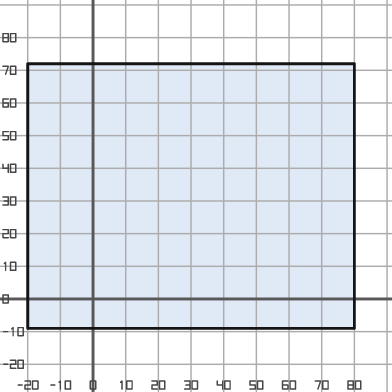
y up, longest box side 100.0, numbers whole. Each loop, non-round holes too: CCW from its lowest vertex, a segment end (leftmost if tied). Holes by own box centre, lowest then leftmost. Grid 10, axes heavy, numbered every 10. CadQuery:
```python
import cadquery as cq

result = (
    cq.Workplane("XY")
    .moveTo(-20.0, -9.0)
    .lineTo(80.0, -9.0)
    .lineTo(80.0, 72.0)
    .lineTo(-20.0, 72.0)
    .close()
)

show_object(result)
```